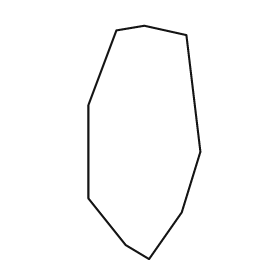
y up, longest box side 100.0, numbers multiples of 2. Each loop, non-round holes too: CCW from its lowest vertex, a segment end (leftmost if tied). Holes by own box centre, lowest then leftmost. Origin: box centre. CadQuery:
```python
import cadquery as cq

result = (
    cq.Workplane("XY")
    .moveTo(2.0, -50.0)
    .lineTo(16.0, -30.0)
    .lineTo(24.0, -4.0)
    .lineTo(18.0, 46.0)
    .lineTo(0.0, 50.0)
    .lineTo(-12.0, 48.0)
    .lineTo(-24.0, 16.0)
    .lineTo(-24.0, -24.0)
    .lineTo(-8.0, -44.0)
    .close()
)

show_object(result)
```